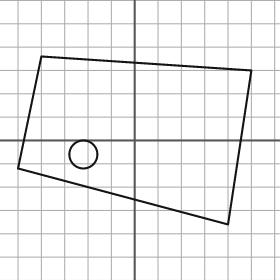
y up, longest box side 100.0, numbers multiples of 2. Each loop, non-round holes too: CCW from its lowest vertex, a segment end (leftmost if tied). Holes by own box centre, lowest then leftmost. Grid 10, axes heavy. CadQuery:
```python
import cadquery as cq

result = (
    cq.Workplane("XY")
    .moveTo(40.0, -36.0)
    .lineTo(50.0, 30.0)
    .lineTo(-40.0, 36.0)
    .lineTo(-50.0, -12.0)
    .close()
    .moveTo(-22.0, -6.0)
    .circle(6.0)
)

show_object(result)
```